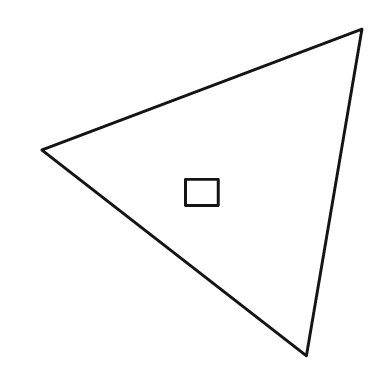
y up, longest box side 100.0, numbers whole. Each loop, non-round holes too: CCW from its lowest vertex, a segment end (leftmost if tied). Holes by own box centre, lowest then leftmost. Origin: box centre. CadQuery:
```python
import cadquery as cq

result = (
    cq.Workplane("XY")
    .moveTo(32.0, -50.0)
    .lineTo(49.0, 50.0)
    .lineTo(-49.0, 13.0)
    .close()
    .moveTo(-5.0, -4.0)
    .lineTo(5.0, -4.0)
    .lineTo(5.0, 4.0)
    .lineTo(-5.0, 4.0)
    .close()
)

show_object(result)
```